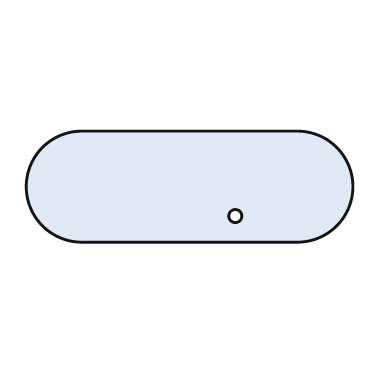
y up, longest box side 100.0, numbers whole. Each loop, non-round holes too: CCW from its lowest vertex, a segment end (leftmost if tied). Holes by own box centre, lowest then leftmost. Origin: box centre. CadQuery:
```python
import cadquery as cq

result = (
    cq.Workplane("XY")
    .moveTo(-33.0, -17.0)
    .lineTo(33.0, -17.0)
    .threePointArc((50.0, 0.0), (33.0, 17.0))
    .lineTo(-33.0, 17.0)
    .threePointArc((-50.0, 0.0), (-33.0, -17.0))
    .close()
    .moveTo(14.0, -9.0)
    .circle(2.0)
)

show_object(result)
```